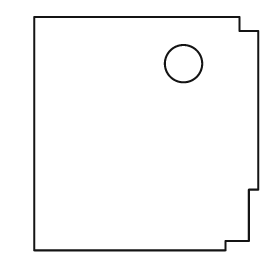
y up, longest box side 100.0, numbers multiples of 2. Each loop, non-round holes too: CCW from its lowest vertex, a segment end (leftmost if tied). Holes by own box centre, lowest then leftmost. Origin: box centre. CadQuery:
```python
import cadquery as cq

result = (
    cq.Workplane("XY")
    .moveTo(-48.0, -50.0)
    .lineTo(34.0, -50.0)
    .lineTo(34.0, -46.0)
    .lineTo(44.0, -46.0)
    .lineTo(44.0, -24.0)
    .lineTo(48.0, -24.0)
    .lineTo(48.0, 44.0)
    .lineTo(40.0, 44.0)
    .lineTo(40.0, 50.0)
    .lineTo(-48.0, 50.0)
    .close()
    .moveTo(16.0, 30.0)
    .circle(8.0)
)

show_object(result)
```